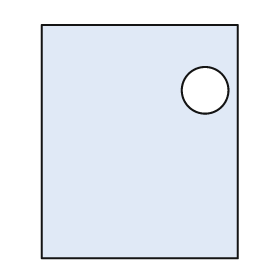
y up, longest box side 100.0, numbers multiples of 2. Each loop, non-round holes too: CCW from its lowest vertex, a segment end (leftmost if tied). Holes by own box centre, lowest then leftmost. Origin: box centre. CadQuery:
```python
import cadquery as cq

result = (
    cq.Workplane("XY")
    .moveTo(-42.0, -50.0)
    .lineTo(42.0, -50.0)
    .lineTo(42.0, 50.0)
    .lineTo(-42.0, 50.0)
    .close()
    .moveTo(28.0, 22.0)
    .circle(10.0)
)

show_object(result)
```